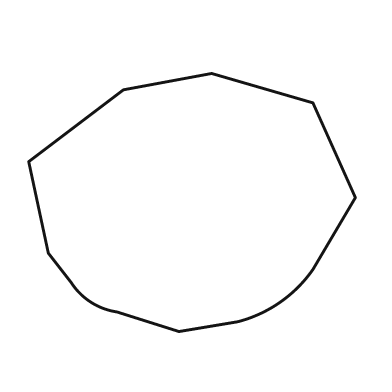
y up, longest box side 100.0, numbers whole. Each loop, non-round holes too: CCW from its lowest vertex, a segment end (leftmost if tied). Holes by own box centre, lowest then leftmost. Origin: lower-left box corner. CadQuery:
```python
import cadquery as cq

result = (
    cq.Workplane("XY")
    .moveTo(46.0, 0.0)
    .lineTo(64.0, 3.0)
    .threePointArc((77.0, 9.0), (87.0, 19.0))
    .lineTo(100.0, 41.0)
    .lineTo(87.0, 70.0)
    .lineTo(56.0, 79.0)
    .lineTo(29.0, 74.0)
    .lineTo(0.0, 52.0)
    .lineTo(6.0, 24.0)
    .lineTo(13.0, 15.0)
    .threePointArc((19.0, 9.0), (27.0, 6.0))
    .close()
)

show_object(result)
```